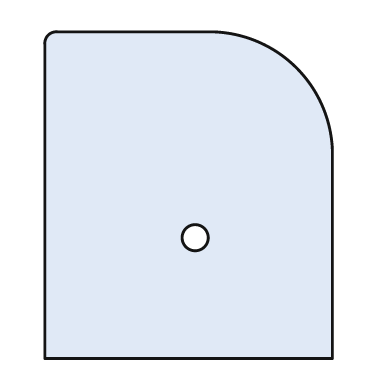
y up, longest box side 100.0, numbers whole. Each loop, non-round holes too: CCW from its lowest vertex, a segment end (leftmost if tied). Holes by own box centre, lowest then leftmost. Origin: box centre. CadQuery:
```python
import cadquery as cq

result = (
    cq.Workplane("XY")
    .moveTo(-44.0, -50.0)
    .lineTo(44.0, -50.0)
    .lineTo(44.0, 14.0)
    .threePointArc((33.0, 39.0), (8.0, 50.0))
    .lineTo(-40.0, 50.0)
    .threePointArc((-43.0, 49.0), (-44.0, 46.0))
    .close()
    .moveTo(2.0, -13.0)
    .circle(4.0)
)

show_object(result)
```